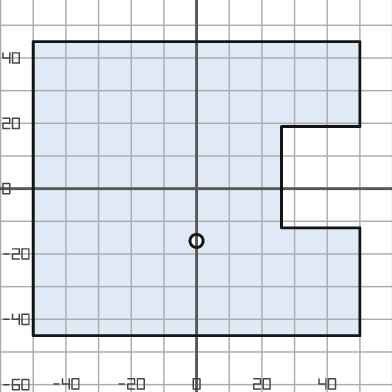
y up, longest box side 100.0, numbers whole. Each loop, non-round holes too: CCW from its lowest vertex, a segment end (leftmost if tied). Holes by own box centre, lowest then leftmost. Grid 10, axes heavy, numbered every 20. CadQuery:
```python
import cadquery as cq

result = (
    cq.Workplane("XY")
    .moveTo(-50.0, -45.0)
    .lineTo(50.0, -45.0)
    .lineTo(50.0, -12.0)
    .lineTo(26.0, -12.0)
    .lineTo(26.0, 19.0)
    .lineTo(50.0, 19.0)
    .lineTo(50.0, 45.0)
    .lineTo(-50.0, 45.0)
    .close()
    .moveTo(0.0, -16.0)
    .circle(2.0)
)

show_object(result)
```